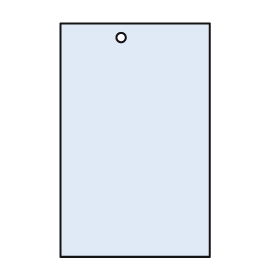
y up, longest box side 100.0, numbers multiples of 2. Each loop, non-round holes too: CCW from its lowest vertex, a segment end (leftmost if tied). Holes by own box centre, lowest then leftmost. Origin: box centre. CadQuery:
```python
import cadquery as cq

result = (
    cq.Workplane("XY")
    .moveTo(-32.0, -50.0)
    .lineTo(32.0, -50.0)
    .lineTo(32.0, 50.0)
    .lineTo(-32.0, 50.0)
    .close()
    .moveTo(-6.0, 44.0)
    .circle(2.0)
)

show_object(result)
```